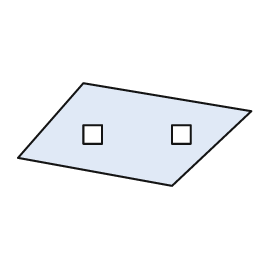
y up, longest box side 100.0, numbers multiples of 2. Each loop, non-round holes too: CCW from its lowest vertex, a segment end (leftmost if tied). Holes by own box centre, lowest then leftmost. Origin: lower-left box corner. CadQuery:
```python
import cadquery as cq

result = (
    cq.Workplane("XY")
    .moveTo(66.0, 0.0)
    .lineTo(100.0, 32.0)
    .lineTo(28.0, 44.0)
    .lineTo(0.0, 12.0)
    .close()
    .moveTo(28.0, 18.0)
    .lineTo(36.0, 18.0)
    .lineTo(36.0, 26.0)
    .lineTo(28.0, 26.0)
    .close()
    .moveTo(66.0, 18.0)
    .lineTo(74.0, 18.0)
    .lineTo(74.0, 26.0)
    .lineTo(66.0, 26.0)
    .close()
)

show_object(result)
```